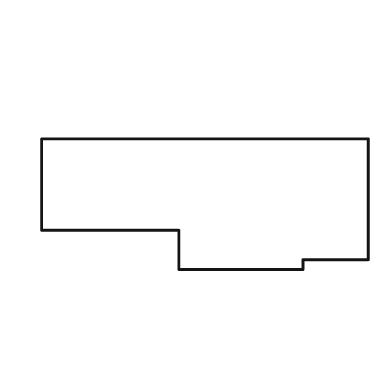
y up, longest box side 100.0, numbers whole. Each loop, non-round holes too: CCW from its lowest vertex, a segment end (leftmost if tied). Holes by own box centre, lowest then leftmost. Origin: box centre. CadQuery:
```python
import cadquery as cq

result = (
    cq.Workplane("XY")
    .moveTo(-8.0, -20.0)
    .lineTo(30.0, -20.0)
    .lineTo(30.0, -17.0)
    .lineTo(50.0, -17.0)
    .lineTo(50.0, 20.0)
    .lineTo(-50.0, 20.0)
    .lineTo(-50.0, -8.0)
    .lineTo(-8.0, -8.0)
    .close()
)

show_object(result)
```